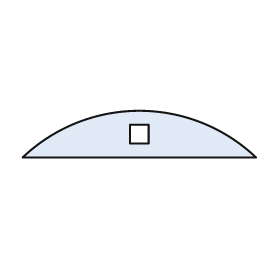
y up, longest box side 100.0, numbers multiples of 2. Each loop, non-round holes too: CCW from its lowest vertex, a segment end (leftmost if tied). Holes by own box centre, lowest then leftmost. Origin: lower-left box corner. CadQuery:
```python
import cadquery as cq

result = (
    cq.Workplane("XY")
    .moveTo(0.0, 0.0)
    .lineTo(100.0, 0.0)
    .threePointArc((50.0, 20.0), (0.0, 0.0))
    .close()
    .moveTo(46.0, 6.0)
    .lineTo(54.0, 6.0)
    .lineTo(54.0, 14.0)
    .lineTo(46.0, 14.0)
    .close()
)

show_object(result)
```